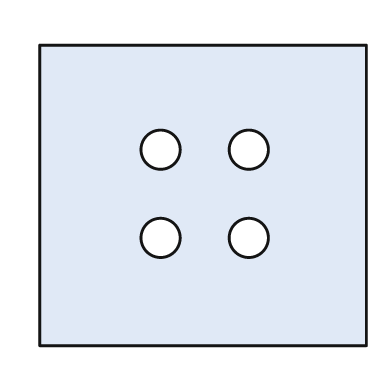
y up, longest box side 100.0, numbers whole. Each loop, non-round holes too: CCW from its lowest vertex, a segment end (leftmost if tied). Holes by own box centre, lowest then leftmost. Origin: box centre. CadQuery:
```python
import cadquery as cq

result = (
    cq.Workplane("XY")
    .moveTo(-50.0, -46.0)
    .lineTo(50.0, -46.0)
    .lineTo(50.0, 46.0)
    .lineTo(-50.0, 46.0)
    .close()
    .moveTo(-13.0, -13.0)
    .circle(6.0)
    .moveTo(14.0, -13.0)
    .circle(6.0)
    .moveTo(-13.0, 14.0)
    .circle(6.0)
    .moveTo(14.0, 14.0)
    .circle(6.0)
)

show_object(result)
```